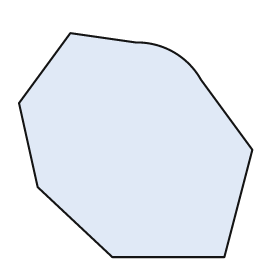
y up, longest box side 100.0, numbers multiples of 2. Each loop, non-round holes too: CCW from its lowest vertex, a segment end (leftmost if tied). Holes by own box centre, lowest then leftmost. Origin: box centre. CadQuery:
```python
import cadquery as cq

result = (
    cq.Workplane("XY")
    .moveTo(-10.0, -48.0)
    .lineTo(38.0, -48.0)
    .lineTo(50.0, -2.0)
    .lineTo(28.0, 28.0)
    .threePointArc((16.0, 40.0), (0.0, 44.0))
    .lineTo(-28.0, 48.0)
    .lineTo(-50.0, 18.0)
    .lineTo(-42.0, -18.0)
    .close()
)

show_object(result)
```